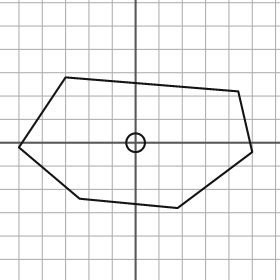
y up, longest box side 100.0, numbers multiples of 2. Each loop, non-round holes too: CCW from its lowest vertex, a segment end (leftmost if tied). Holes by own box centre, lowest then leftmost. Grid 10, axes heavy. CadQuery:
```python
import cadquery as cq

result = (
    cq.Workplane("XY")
    .moveTo(18.0, -28.0)
    .lineTo(50.0, -4.0)
    .lineTo(44.0, 22.0)
    .lineTo(-30.0, 28.0)
    .lineTo(-50.0, -2.0)
    .lineTo(-24.0, -24.0)
    .close()
    .moveTo(0.0, 0.0)
    .circle(4.0)
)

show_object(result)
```